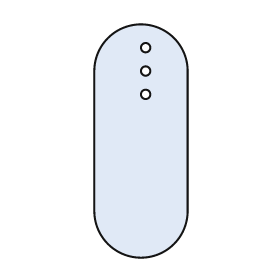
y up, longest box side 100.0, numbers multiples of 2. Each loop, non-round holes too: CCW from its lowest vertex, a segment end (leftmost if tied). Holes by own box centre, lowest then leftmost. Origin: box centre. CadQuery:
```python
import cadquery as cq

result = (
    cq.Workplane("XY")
    .moveTo(-20.0, -30.0)
    .threePointArc((0.0, -50.0), (20.0, -30.0))
    .lineTo(20.0, 30.0)
    .threePointArc((0.0, 50.0), (-20.0, 30.0))
    .close()
    .moveTo(2.0, 20.0)
    .circle(2.0)
    .moveTo(2.0, 30.0)
    .circle(2.0)
    .moveTo(2.0, 40.0)
    .circle(2.0)
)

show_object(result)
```